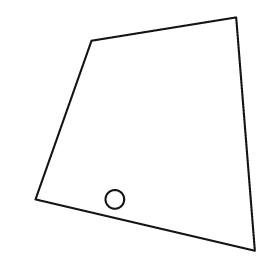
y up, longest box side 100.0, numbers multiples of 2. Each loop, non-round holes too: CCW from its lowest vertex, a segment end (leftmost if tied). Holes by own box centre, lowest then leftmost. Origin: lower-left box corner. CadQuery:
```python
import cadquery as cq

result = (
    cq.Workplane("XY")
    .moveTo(94.0, 0.0)
    .lineTo(86.0, 100.0)
    .lineTo(24.0, 90.0)
    .lineTo(0.0, 22.0)
    .close()
    .moveTo(34.0, 22.0)
    .circle(4.0)
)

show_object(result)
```